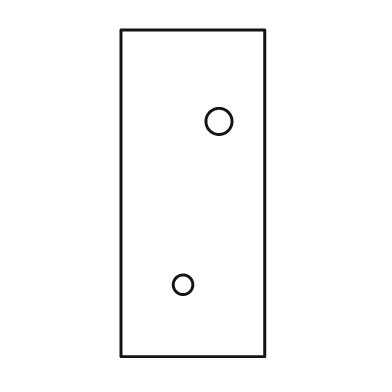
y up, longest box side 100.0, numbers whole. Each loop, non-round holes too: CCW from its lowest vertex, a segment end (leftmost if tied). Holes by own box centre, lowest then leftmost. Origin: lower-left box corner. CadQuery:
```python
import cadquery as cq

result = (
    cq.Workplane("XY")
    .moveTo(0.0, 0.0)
    .lineTo(44.0, 0.0)
    .lineTo(44.0, 100.0)
    .lineTo(0.0, 100.0)
    .close()
    .moveTo(19.0, 22.0)
    .circle(3.0)
    .moveTo(30.0, 72.0)
    .circle(4.0)
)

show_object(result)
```